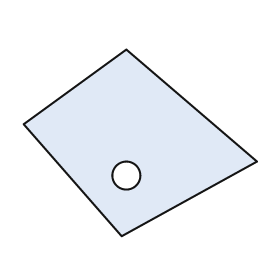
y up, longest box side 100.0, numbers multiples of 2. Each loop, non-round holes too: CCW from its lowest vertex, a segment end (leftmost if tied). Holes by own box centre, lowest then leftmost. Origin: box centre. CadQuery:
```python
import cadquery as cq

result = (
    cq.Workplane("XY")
    .moveTo(-8.0, -40.0)
    .lineTo(50.0, -8.0)
    .lineTo(-6.0, 40.0)
    .lineTo(-50.0, 8.0)
    .close()
    .moveTo(-6.0, -14.0)
    .circle(6.0)
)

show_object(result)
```